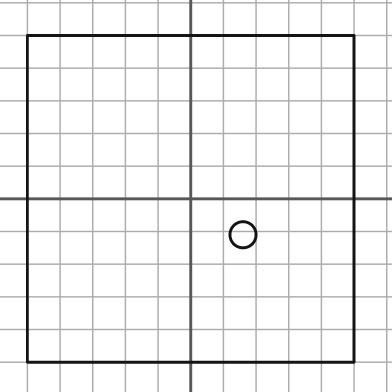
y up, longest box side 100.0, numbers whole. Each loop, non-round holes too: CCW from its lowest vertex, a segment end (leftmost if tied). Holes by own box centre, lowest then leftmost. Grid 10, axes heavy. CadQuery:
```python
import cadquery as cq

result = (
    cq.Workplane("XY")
    .moveTo(-50.0, -50.0)
    .lineTo(50.0, -50.0)
    .lineTo(50.0, 50.0)
    .lineTo(-50.0, 50.0)
    .close()
    .moveTo(16.0, -11.0)
    .circle(4.0)
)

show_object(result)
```